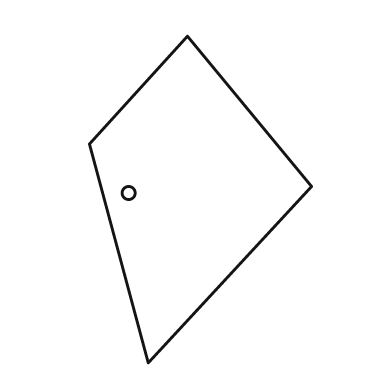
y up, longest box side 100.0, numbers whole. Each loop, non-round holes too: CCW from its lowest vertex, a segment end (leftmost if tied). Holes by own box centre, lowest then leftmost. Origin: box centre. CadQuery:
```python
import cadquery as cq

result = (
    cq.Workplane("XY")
    .moveTo(-16.0, -50.0)
    .lineTo(34.0, 4.0)
    .lineTo(-4.0, 50.0)
    .lineTo(-34.0, 17.0)
    .close()
    .moveTo(-22.0, 2.0)
    .circle(2.0)
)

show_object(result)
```